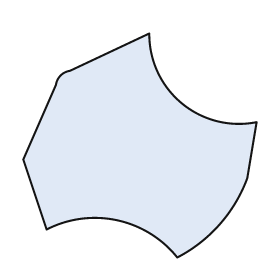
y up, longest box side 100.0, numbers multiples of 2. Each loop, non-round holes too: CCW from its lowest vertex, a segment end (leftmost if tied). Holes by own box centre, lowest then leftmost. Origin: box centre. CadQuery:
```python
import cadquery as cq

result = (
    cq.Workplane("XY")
    .moveTo(16.0, -48.0)
    .threePointArc((34.0, -34.0), (46.0, -14.0))
    .lineTo(50.0, 10.0)
    .threePointArc((18.0, 18.0), (4.0, 48.0))
    .lineTo(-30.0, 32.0)
    .threePointArc((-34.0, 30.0), (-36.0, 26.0))
    .lineTo(-50.0, -6.0)
    .lineTo(-40.0, -36.0)
    .threePointArc((-10.0, -32.0), (16.0, -48.0))
    .close()
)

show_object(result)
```